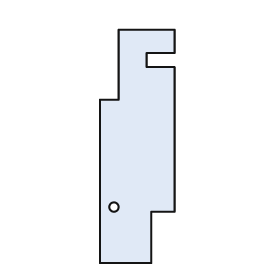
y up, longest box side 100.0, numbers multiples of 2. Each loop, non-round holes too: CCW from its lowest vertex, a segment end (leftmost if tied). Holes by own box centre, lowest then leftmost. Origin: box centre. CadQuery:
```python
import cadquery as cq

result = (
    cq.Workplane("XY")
    .moveTo(-16.0, -50.0)
    .lineTo(6.0, -50.0)
    .lineTo(6.0, -28.0)
    .lineTo(16.0, -28.0)
    .lineTo(16.0, 34.0)
    .lineTo(4.0, 34.0)
    .lineTo(4.0, 40.0)
    .lineTo(16.0, 40.0)
    .lineTo(16.0, 50.0)
    .lineTo(-8.0, 50.0)
    .lineTo(-8.0, 20.0)
    .lineTo(-16.0, 20.0)
    .close()
    .moveTo(-10.0, -26.0)
    .circle(2.0)
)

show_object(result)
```